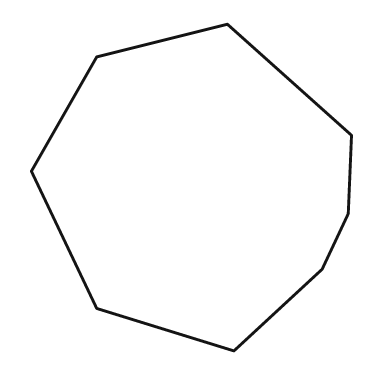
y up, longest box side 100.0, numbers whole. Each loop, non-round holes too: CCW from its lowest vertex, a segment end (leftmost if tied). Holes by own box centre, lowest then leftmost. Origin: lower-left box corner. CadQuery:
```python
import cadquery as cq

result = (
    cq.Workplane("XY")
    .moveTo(62.0, 0.0)
    .lineTo(89.0, 25.0)
    .lineTo(97.0, 42.0)
    .lineTo(98.0, 66.0)
    .lineTo(60.0, 100.0)
    .lineTo(20.0, 90.0)
    .lineTo(0.0, 55.0)
    .lineTo(20.0, 13.0)
    .close()
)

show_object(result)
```